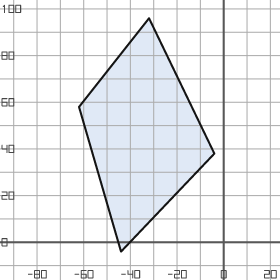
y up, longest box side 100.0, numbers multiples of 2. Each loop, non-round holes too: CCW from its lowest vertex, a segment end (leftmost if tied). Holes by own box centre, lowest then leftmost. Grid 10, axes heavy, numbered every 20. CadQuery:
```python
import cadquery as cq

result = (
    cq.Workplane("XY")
    .moveTo(-44.0, -4.0)
    .lineTo(-4.0, 38.0)
    .lineTo(-32.0, 96.0)
    .lineTo(-62.0, 58.0)
    .close()
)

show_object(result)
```